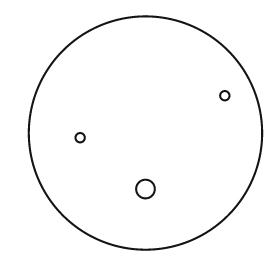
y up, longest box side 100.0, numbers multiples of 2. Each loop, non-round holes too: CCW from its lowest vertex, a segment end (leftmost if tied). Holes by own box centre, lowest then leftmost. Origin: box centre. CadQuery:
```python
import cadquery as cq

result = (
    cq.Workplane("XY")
    .moveTo(0.0, 0.0)
    .circle(50.0)
    .moveTo(0.0, -24.0)
    .circle(4.0)
    .moveTo(-28.0, -2.0)
    .circle(2.0)
    .moveTo(34.0, 16.0)
    .circle(2.0)
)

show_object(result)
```